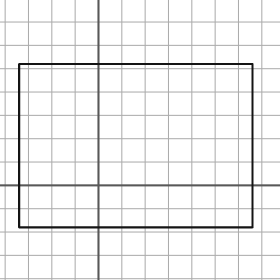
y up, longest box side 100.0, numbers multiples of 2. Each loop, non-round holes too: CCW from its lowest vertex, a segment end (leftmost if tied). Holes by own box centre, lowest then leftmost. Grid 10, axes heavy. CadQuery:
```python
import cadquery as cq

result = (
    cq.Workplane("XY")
    .moveTo(-34.0, -18.0)
    .lineTo(66.0, -18.0)
    .lineTo(66.0, 52.0)
    .lineTo(-34.0, 52.0)
    .close()
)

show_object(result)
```